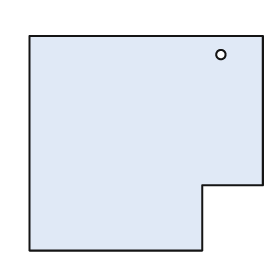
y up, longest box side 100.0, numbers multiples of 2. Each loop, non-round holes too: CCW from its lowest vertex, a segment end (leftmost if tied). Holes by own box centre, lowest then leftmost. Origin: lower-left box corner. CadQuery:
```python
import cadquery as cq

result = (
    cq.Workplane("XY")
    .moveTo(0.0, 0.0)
    .lineTo(74.0, 0.0)
    .lineTo(74.0, 28.0)
    .lineTo(100.0, 28.0)
    .lineTo(100.0, 92.0)
    .lineTo(0.0, 92.0)
    .close()
    .moveTo(82.0, 84.0)
    .circle(2.0)
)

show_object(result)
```